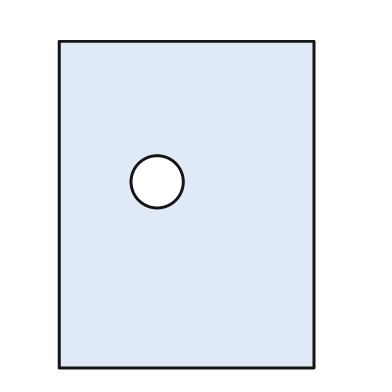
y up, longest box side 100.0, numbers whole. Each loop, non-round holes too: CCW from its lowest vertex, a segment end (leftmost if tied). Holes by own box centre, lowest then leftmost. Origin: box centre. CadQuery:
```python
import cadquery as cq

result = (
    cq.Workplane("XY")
    .moveTo(-39.0, -50.0)
    .lineTo(39.0, -50.0)
    .lineTo(39.0, 50.0)
    .lineTo(-39.0, 50.0)
    .close()
    .moveTo(-9.0, 7.0)
    .circle(8.0)
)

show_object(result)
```